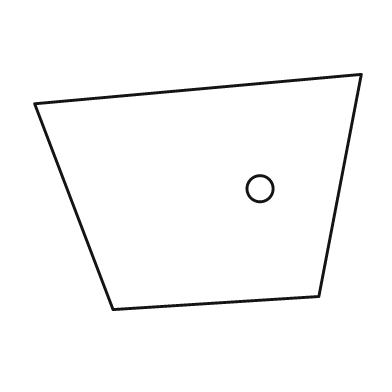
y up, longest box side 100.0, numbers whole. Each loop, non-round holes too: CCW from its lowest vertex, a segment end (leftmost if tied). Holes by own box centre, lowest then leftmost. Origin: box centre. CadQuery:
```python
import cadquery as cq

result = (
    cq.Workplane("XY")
    .moveTo(-26.0, -36.0)
    .lineTo(37.0, -32.0)
    .lineTo(50.0, 36.0)
    .lineTo(-50.0, 27.0)
    .close()
    .moveTo(19.0, 1.0)
    .circle(4.0)
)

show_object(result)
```